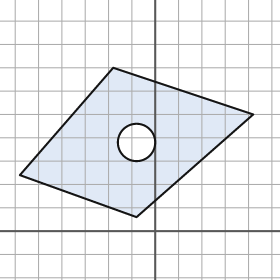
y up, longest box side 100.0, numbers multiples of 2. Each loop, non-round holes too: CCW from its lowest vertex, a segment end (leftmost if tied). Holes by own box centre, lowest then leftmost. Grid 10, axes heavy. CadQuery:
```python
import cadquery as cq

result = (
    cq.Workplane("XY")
    .moveTo(-8.0, 6.0)
    .lineTo(42.0, 50.0)
    .lineTo(-18.0, 70.0)
    .lineTo(-58.0, 24.0)
    .close()
    .moveTo(-8.0, 38.0)
    .circle(8.0)
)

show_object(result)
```